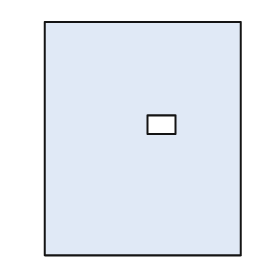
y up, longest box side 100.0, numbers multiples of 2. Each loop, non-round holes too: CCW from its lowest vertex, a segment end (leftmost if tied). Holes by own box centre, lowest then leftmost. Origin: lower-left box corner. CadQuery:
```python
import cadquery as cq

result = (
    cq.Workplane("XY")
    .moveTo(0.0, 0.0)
    .lineTo(84.0, 0.0)
    .lineTo(84.0, 100.0)
    .lineTo(0.0, 100.0)
    .close()
    .moveTo(44.0, 52.0)
    .lineTo(56.0, 52.0)
    .lineTo(56.0, 60.0)
    .lineTo(44.0, 60.0)
    .close()
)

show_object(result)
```